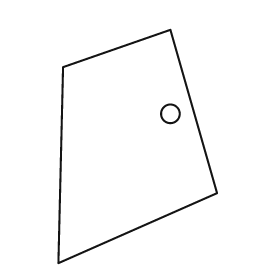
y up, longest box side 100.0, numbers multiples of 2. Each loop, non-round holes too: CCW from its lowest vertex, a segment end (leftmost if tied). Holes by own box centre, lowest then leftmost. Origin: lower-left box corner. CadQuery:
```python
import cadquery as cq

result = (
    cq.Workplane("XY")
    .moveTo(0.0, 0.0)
    .lineTo(68.0, 30.0)
    .lineTo(48.0, 100.0)
    .lineTo(2.0, 84.0)
    .close()
    .moveTo(48.0, 64.0)
    .circle(4.0)
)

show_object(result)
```